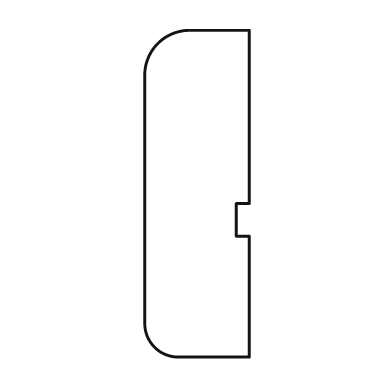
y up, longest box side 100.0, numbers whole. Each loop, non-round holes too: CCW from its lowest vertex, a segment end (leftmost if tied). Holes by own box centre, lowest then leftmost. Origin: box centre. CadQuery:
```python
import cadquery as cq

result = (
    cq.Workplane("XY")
    .moveTo(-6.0, -50.0)
    .lineTo(16.0, -50.0)
    .lineTo(16.0, -13.0)
    .lineTo(12.0, -13.0)
    .lineTo(12.0, -3.0)
    .lineTo(16.0, -3.0)
    .lineTo(16.0, 50.0)
    .lineTo(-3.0, 50.0)
    .threePointArc((-12.0, 46.0), (-16.0, 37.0))
    .lineTo(-16.0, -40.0)
    .threePointArc((-13.0, -47.0), (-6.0, -50.0))
    .close()
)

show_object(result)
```